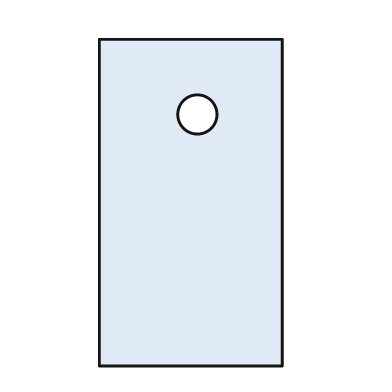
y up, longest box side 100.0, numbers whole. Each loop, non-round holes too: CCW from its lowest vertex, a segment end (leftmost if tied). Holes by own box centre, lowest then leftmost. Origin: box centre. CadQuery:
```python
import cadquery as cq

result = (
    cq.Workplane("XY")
    .moveTo(-28.0, -50.0)
    .lineTo(28.0, -50.0)
    .lineTo(28.0, 50.0)
    .lineTo(-28.0, 50.0)
    .close()
    .moveTo(2.0, 27.0)
    .circle(6.0)
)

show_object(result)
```